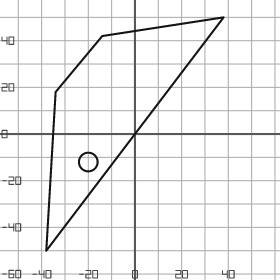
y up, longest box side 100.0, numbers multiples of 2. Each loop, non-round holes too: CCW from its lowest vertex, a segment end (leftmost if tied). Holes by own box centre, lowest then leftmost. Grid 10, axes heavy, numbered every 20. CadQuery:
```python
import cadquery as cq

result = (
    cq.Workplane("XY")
    .moveTo(-38.0, -50.0)
    .lineTo(38.0, 50.0)
    .lineTo(-14.0, 42.0)
    .lineTo(-34.0, 18.0)
    .close()
    .moveTo(-20.0, -12.0)
    .circle(4.0)
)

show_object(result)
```